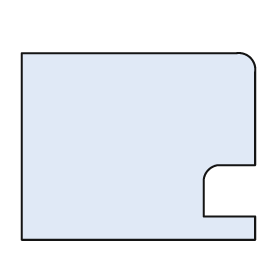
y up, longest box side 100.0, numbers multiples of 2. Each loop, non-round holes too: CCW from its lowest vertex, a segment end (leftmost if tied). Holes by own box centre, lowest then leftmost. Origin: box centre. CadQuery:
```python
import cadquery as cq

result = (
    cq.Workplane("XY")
    .moveTo(-50.0, -40.0)
    .lineTo(50.0, -40.0)
    .lineTo(50.0, -30.0)
    .lineTo(28.0, -30.0)
    .lineTo(28.0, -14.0)
    .threePointArc((30.0, -10.0), (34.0, -8.0))
    .lineTo(50.0, -8.0)
    .lineTo(50.0, 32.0)
    .threePointArc((48.0, 38.0), (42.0, 40.0))
    .lineTo(-50.0, 40.0)
    .close()
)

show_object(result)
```